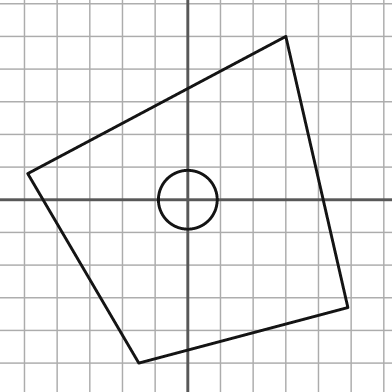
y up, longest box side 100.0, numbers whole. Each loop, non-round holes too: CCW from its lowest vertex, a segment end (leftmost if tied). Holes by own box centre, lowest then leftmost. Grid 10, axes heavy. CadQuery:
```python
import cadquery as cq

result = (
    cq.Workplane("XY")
    .moveTo(-15.0, -50.0)
    .lineTo(49.0, -33.0)
    .lineTo(30.0, 50.0)
    .lineTo(-49.0, 8.0)
    .close()
    .moveTo(0.0, 0.0)
    .circle(9.0)
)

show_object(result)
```